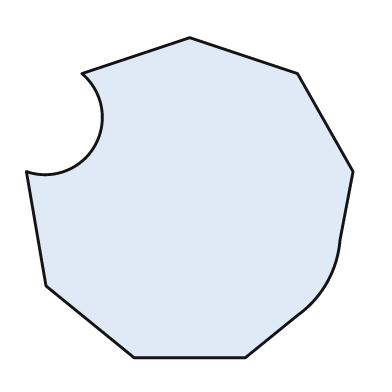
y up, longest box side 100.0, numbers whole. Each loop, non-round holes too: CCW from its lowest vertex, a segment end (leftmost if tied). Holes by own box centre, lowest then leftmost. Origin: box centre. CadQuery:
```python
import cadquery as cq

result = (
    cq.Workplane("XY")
    .moveTo(-17.0, -49.0)
    .lineTo(17.0, -49.0)
    .lineTo(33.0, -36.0)
    .threePointArc((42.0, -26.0), (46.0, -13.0))
    .lineTo(50.0, 8.0)
    .lineTo(33.0, 38.0)
    .lineTo(0.0, 49.0)
    .lineTo(-33.0, 38.0)
    .threePointArc((-29.0, 16.0), (-50.0, 8.0))
    .lineTo(-44.0, -27.0)
    .close()
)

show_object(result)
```